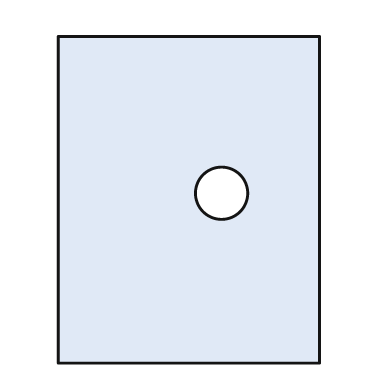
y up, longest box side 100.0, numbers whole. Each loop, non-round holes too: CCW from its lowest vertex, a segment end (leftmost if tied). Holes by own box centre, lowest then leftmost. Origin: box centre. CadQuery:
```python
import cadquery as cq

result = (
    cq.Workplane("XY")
    .moveTo(-40.0, -50.0)
    .lineTo(40.0, -50.0)
    .lineTo(40.0, 50.0)
    .lineTo(-40.0, 50.0)
    .close()
    .moveTo(10.0, 2.0)
    .circle(8.0)
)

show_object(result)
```